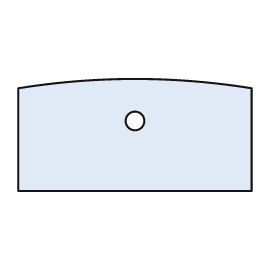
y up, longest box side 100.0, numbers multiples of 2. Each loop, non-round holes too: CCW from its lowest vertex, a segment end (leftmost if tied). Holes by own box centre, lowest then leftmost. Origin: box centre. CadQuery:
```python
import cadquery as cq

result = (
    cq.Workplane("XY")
    .moveTo(-50.0, -24.0)
    .lineTo(50.0, -24.0)
    .lineTo(50.0, 20.0)
    .threePointArc((0.0, 24.0), (-50.0, 20.0))
    .close()
    .moveTo(0.0, 6.0)
    .circle(4.0)
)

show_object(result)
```